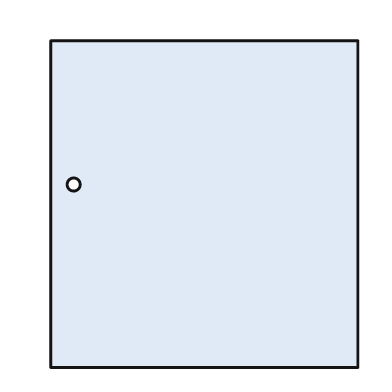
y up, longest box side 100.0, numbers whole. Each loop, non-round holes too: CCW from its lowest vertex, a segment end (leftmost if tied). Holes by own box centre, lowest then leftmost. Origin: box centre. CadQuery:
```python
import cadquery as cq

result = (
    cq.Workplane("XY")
    .moveTo(-47.0, -50.0)
    .lineTo(47.0, -50.0)
    .lineTo(47.0, 50.0)
    .lineTo(-47.0, 50.0)
    .close()
    .moveTo(-40.0, 6.0)
    .circle(2.0)
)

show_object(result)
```